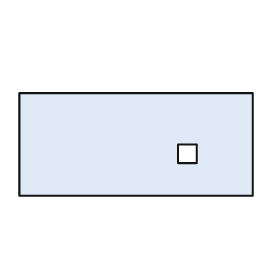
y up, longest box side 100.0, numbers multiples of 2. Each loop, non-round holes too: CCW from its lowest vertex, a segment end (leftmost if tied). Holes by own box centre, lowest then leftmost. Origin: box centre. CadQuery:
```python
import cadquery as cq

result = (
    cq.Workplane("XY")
    .moveTo(-50.0, -22.0)
    .lineTo(50.0, -22.0)
    .lineTo(50.0, 22.0)
    .lineTo(-50.0, 22.0)
    .close()
    .moveTo(18.0, -8.0)
    .lineTo(26.0, -8.0)
    .lineTo(26.0, 0.0)
    .lineTo(18.0, 0.0)
    .close()
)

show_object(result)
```